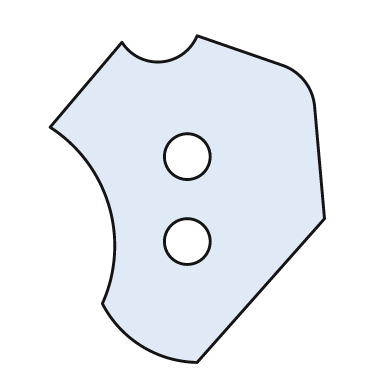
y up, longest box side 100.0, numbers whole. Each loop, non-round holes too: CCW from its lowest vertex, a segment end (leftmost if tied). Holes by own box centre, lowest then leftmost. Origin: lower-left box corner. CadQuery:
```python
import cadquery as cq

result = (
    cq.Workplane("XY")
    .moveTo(45.0, 0.0)
    .lineTo(84.0, 44.0)
    .lineTo(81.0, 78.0)
    .threePointArc((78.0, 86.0), (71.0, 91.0))
    .lineTo(45.0, 100.0)
    .threePointArc((34.0, 92.0), (22.0, 98.0))
    .lineTo(0.0, 72.0)
    .threePointArc((18.0, 48.0), (16.0, 18.0))
    .threePointArc((28.0, 5.0), (45.0, 0.0))
    .close()
    .moveTo(42.0, 37.0)
    .circle(7.0)
    .moveTo(42.0, 63.0)
    .circle(7.0)
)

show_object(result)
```